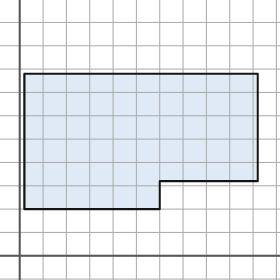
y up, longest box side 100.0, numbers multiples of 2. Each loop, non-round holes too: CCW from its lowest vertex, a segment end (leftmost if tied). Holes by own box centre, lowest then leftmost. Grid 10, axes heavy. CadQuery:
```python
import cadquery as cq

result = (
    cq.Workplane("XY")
    .moveTo(2.0, 20.0)
    .lineTo(60.0, 20.0)
    .lineTo(60.0, 32.0)
    .lineTo(102.0, 32.0)
    .lineTo(102.0, 78.0)
    .lineTo(2.0, 78.0)
    .close()
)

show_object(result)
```